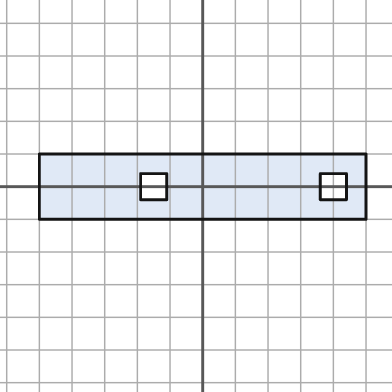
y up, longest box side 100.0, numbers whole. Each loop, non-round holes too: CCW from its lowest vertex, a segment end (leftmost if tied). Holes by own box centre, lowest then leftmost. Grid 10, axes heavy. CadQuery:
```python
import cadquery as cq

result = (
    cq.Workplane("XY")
    .moveTo(-50.0, -10.0)
    .lineTo(50.0, -10.0)
    .lineTo(50.0, 10.0)
    .lineTo(-50.0, 10.0)
    .close()
    .moveTo(-19.0, -4.0)
    .lineTo(-11.0, -4.0)
    .lineTo(-11.0, 4.0)
    .lineTo(-19.0, 4.0)
    .close()
    .moveTo(36.0, -4.0)
    .lineTo(44.0, -4.0)
    .lineTo(44.0, 4.0)
    .lineTo(36.0, 4.0)
    .close()
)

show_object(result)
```